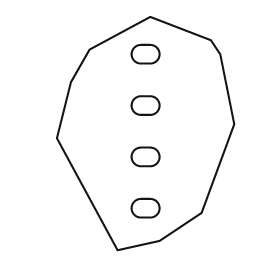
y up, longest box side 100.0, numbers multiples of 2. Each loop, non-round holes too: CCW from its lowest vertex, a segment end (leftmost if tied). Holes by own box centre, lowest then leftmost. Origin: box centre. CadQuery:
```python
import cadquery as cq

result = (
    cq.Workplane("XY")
    .moveTo(-12.0, -50.0)
    .lineTo(6.0, -46.0)
    .lineTo(24.0, -34.0)
    .lineTo(38.0, 4.0)
    .lineTo(32.0, 34.0)
    .lineTo(28.0, 40.0)
    .lineTo(2.0, 50.0)
    .lineTo(-24.0, 36.0)
    .lineTo(-32.0, 22.0)
    .lineTo(-38.0, -2.0)
    .close()
    .moveTo(-2.0, -36.0)
    .lineTo(2.0, -36.0)
    .threePointArc((6.0, -32.0), (2.0, -28.0))
    .lineTo(-2.0, -28.0)
    .threePointArc((-6.0, -32.0), (-2.0, -36.0))
    .close()
    .moveTo(-2.0, -14.0)
    .lineTo(2.0, -14.0)
    .threePointArc((6.0, -10.0), (2.0, -6.0))
    .lineTo(-2.0, -6.0)
    .threePointArc((-6.0, -10.0), (-2.0, -14.0))
    .close()
    .moveTo(-2.0, 8.0)
    .lineTo(2.0, 8.0)
    .threePointArc((6.0, 12.0), (2.0, 16.0))
    .lineTo(-2.0, 16.0)
    .threePointArc((-6.0, 12.0), (-2.0, 8.0))
    .close()
    .moveTo(-2.0, 30.0)
    .lineTo(2.0, 30.0)
    .threePointArc((6.0, 34.0), (2.0, 38.0))
    .lineTo(-2.0, 38.0)
    .threePointArc((-6.0, 34.0), (-2.0, 30.0))
    .close()
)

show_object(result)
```